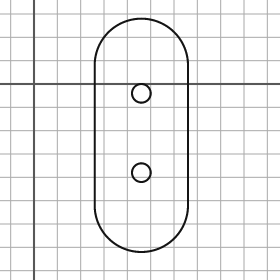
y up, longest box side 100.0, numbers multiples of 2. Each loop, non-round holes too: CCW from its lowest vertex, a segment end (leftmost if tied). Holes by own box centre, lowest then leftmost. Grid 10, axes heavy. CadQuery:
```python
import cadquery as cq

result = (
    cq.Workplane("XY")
    .moveTo(26.0, -52.0)
    .threePointArc((46.0, -72.0), (66.0, -52.0))
    .lineTo(66.0, 8.0)
    .threePointArc((46.0, 28.0), (26.0, 8.0))
    .close()
    .moveTo(46.0, -38.0)
    .circle(4.0)
    .moveTo(46.0, -4.0)
    .circle(4.0)
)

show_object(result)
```